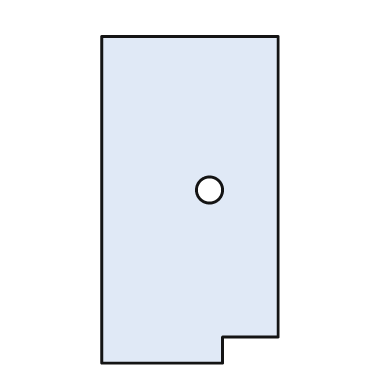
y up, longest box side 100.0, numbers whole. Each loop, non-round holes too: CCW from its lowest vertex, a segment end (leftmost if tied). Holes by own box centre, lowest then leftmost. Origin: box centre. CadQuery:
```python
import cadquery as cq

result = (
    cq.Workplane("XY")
    .moveTo(-27.0, -50.0)
    .lineTo(10.0, -50.0)
    .lineTo(10.0, -42.0)
    .lineTo(27.0, -42.0)
    .lineTo(27.0, 50.0)
    .lineTo(-27.0, 50.0)
    .close()
    .moveTo(6.0, 3.0)
    .circle(4.0)
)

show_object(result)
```